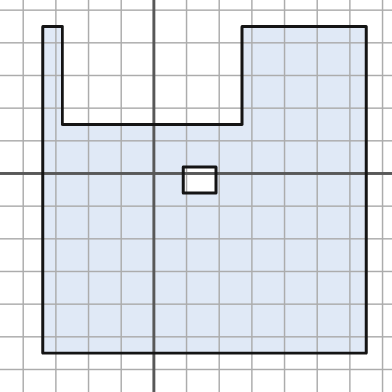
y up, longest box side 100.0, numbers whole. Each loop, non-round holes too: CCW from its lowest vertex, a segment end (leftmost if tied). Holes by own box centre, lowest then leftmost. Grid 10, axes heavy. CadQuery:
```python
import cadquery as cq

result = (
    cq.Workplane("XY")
    .moveTo(-34.0, -55.0)
    .lineTo(65.0, -55.0)
    .lineTo(65.0, 45.0)
    .lineTo(27.0, 45.0)
    .lineTo(27.0, 15.0)
    .lineTo(-28.0, 15.0)
    .lineTo(-28.0, 45.0)
    .lineTo(-34.0, 45.0)
    .close()
    .moveTo(9.0, -6.0)
    .lineTo(19.0, -6.0)
    .lineTo(19.0, 2.0)
    .lineTo(9.0, 2.0)
    .close()
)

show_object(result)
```